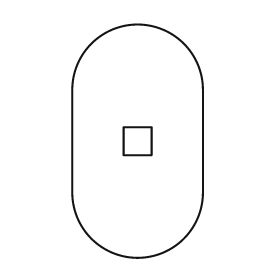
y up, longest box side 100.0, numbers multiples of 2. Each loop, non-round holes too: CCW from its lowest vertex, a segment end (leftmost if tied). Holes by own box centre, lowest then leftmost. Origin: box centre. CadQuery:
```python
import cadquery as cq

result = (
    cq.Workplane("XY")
    .moveTo(-28.0, -22.0)
    .threePointArc((0.0, -50.0), (28.0, -22.0))
    .lineTo(28.0, 22.0)
    .threePointArc((0.0, 50.0), (-28.0, 22.0))
    .close()
    .moveTo(-6.0, -6.0)
    .lineTo(6.0, -6.0)
    .lineTo(6.0, 6.0)
    .lineTo(-6.0, 6.0)
    .close()
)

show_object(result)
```